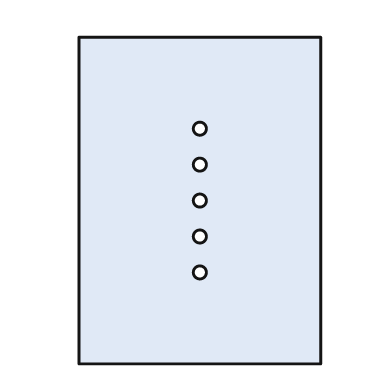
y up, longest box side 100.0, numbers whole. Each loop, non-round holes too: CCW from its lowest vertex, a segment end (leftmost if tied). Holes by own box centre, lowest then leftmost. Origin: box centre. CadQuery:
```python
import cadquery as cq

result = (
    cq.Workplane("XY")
    .moveTo(-37.0, -50.0)
    .lineTo(37.0, -50.0)
    .lineTo(37.0, 50.0)
    .lineTo(-37.0, 50.0)
    .close()
    .moveTo(0.0, -22.0)
    .circle(2.0)
    .moveTo(0.0, -11.0)
    .circle(2.0)
    .moveTo(0.0, 0.0)
    .circle(2.0)
    .moveTo(0.0, 11.0)
    .circle(2.0)
    .moveTo(0.0, 22.0)
    .circle(2.0)
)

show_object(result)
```